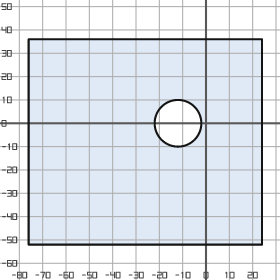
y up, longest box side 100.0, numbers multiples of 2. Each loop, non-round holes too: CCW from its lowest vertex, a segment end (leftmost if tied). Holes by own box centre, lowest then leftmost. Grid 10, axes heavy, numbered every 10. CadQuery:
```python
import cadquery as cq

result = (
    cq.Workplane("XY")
    .moveTo(-76.0, -52.0)
    .lineTo(24.0, -52.0)
    .lineTo(24.0, 36.0)
    .lineTo(-76.0, 36.0)
    .close()
    .moveTo(-12.0, 0.0)
    .circle(10.0)
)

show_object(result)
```